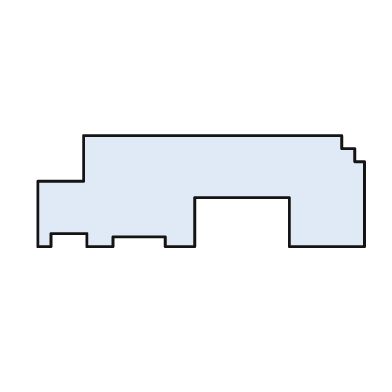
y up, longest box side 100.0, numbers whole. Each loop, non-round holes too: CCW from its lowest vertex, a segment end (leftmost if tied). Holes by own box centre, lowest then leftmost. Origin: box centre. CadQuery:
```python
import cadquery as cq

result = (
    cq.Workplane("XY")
    .moveTo(-50.0, -17.0)
    .lineTo(-46.0, -17.0)
    .lineTo(-46.0, -13.0)
    .lineTo(-35.0, -13.0)
    .lineTo(-35.0, -17.0)
    .lineTo(-27.0, -17.0)
    .lineTo(-27.0, -14.0)
    .lineTo(-11.0, -14.0)
    .lineTo(-11.0, -17.0)
    .lineTo(-2.0, -17.0)
    .lineTo(-2.0, -2.0)
    .lineTo(27.0, -2.0)
    .lineTo(27.0, -17.0)
    .lineTo(50.0, -17.0)
    .lineTo(50.0, 9.0)
    .lineTo(47.0, 9.0)
    .lineTo(47.0, 13.0)
    .lineTo(43.0, 13.0)
    .lineTo(43.0, 17.0)
    .lineTo(-36.0, 17.0)
    .lineTo(-36.0, 3.0)
    .lineTo(-50.0, 3.0)
    .close()
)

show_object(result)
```